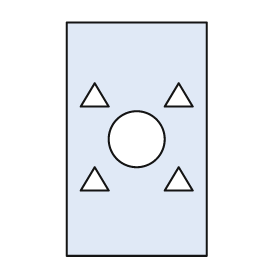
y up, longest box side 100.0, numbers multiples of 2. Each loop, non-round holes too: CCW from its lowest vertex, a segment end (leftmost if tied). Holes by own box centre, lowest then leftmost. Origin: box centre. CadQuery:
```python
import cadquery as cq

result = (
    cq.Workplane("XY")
    .moveTo(-30.0, -50.0)
    .lineTo(30.0, -50.0)
    .lineTo(30.0, 50.0)
    .lineTo(-30.0, 50.0)
    .close()
    .moveTo(-24.0, -22.0)
    .lineTo(-12.0, -22.0)
    .lineTo(-18.0, -12.0)
    .close()
    .moveTo(12.0, -22.0)
    .lineTo(24.0, -22.0)
    .lineTo(18.0, -12.0)
    .close()
    .moveTo(0.0, 0.0)
    .circle(12.0)
    .moveTo(-24.0, 14.0)
    .lineTo(-12.0, 14.0)
    .lineTo(-18.0, 24.0)
    .close()
    .moveTo(12.0, 14.0)
    .lineTo(24.0, 14.0)
    .lineTo(18.0, 24.0)
    .close()
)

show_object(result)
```